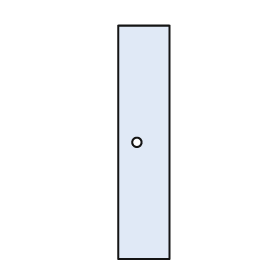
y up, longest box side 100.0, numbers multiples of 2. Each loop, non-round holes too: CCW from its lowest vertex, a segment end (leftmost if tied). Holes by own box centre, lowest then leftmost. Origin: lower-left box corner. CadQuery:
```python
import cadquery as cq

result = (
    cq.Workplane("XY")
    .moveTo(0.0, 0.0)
    .lineTo(22.0, 0.0)
    .lineTo(22.0, 100.0)
    .lineTo(0.0, 100.0)
    .close()
    .moveTo(8.0, 50.0)
    .circle(2.0)
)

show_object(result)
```